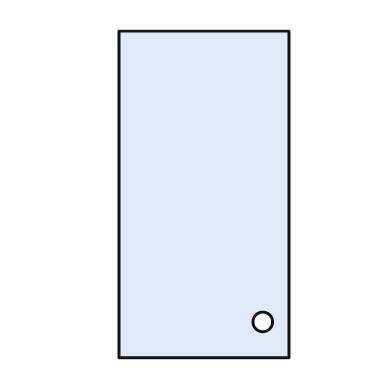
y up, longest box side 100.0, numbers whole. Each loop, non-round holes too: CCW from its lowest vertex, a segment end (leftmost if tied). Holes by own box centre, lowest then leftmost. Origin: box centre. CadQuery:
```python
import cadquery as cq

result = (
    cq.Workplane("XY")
    .moveTo(-26.0, -50.0)
    .lineTo(26.0, -50.0)
    .lineTo(26.0, 50.0)
    .lineTo(-26.0, 50.0)
    .close()
    .moveTo(18.0, -39.0)
    .circle(3.0)
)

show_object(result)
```